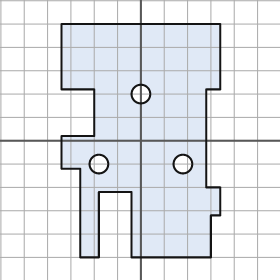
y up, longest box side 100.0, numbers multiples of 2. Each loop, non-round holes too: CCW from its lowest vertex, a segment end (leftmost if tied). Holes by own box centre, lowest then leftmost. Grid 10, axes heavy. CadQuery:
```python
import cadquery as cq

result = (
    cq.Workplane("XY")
    .moveTo(-26.0, -50.0)
    .lineTo(-18.0, -50.0)
    .lineTo(-18.0, -22.0)
    .lineTo(-4.0, -22.0)
    .lineTo(-4.0, -50.0)
    .lineTo(30.0, -50.0)
    .lineTo(30.0, -32.0)
    .lineTo(34.0, -32.0)
    .lineTo(34.0, -20.0)
    .lineTo(28.0, -20.0)
    .lineTo(28.0, 22.0)
    .lineTo(34.0, 22.0)
    .lineTo(34.0, 50.0)
    .lineTo(-34.0, 50.0)
    .lineTo(-34.0, 22.0)
    .lineTo(-20.0, 22.0)
    .lineTo(-20.0, 2.0)
    .lineTo(-34.0, 2.0)
    .lineTo(-34.0, -12.0)
    .lineTo(-26.0, -12.0)
    .close()
    .moveTo(-18.0, -10.0)
    .circle(4.0)
    .moveTo(18.0, -10.0)
    .circle(4.0)
    .moveTo(0.0, 20.0)
    .circle(4.0)
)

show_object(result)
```